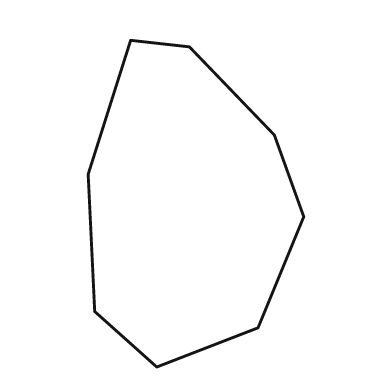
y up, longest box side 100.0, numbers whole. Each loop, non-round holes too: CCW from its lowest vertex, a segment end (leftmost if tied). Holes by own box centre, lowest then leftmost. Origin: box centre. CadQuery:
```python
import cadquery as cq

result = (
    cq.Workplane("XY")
    .moveTo(-12.0, -50.0)
    .lineTo(19.0, -38.0)
    .lineTo(33.0, -4.0)
    .lineTo(24.0, 21.0)
    .lineTo(-2.0, 48.0)
    .lineTo(-20.0, 50.0)
    .lineTo(-33.0, 9.0)
    .lineTo(-31.0, -33.0)
    .close()
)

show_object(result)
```